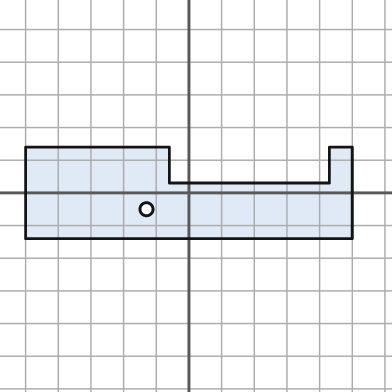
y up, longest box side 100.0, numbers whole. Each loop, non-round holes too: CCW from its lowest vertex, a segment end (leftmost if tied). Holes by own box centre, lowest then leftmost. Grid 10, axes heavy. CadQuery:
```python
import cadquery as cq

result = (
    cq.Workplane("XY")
    .moveTo(-50.0, -14.0)
    .lineTo(50.0, -14.0)
    .lineTo(50.0, 14.0)
    .lineTo(43.0, 14.0)
    .lineTo(43.0, 3.0)
    .lineTo(-6.0, 3.0)
    .lineTo(-6.0, 14.0)
    .lineTo(-50.0, 14.0)
    .close()
    .moveTo(-13.0, -5.0)
    .circle(2.0)
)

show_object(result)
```